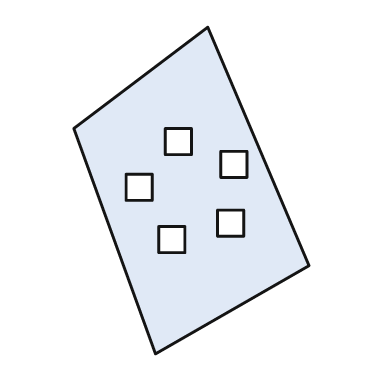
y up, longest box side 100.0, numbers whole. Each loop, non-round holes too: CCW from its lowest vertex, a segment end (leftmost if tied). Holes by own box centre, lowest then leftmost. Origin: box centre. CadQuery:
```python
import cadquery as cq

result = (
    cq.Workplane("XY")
    .moveTo(-11.0, -50.0)
    .lineTo(36.0, -23.0)
    .lineTo(5.0, 50.0)
    .lineTo(-36.0, 19.0)
    .close()
    .moveTo(-10.0, -19.0)
    .lineTo(-2.0, -19.0)
    .lineTo(-2.0, -11.0)
    .lineTo(-10.0, -11.0)
    .close()
    .moveTo(8.0, -14.0)
    .lineTo(16.0, -14.0)
    .lineTo(16.0, -6.0)
    .lineTo(8.0, -6.0)
    .close()
    .moveTo(-20.0, -3.0)
    .lineTo(-12.0, -3.0)
    .lineTo(-12.0, 5.0)
    .lineTo(-20.0, 5.0)
    .close()
    .moveTo(9.0, 4.0)
    .lineTo(17.0, 4.0)
    .lineTo(17.0, 12.0)
    .lineTo(9.0, 12.0)
    .close()
    .moveTo(-8.0, 11.0)
    .lineTo(0.0, 11.0)
    .lineTo(0.0, 19.0)
    .lineTo(-8.0, 19.0)
    .close()
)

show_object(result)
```